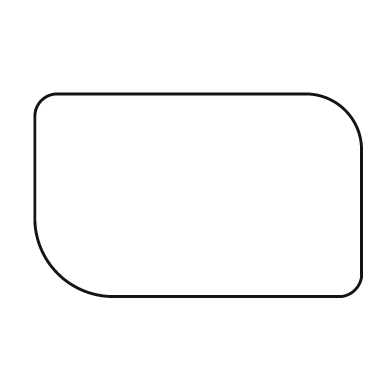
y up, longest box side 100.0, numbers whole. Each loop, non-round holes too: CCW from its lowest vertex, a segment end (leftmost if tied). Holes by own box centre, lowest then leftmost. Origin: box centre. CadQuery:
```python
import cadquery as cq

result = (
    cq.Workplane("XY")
    .moveTo(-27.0, -31.0)
    .lineTo(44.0, -31.0)
    .threePointArc((48.0, -29.0), (50.0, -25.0))
    .lineTo(50.0, 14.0)
    .threePointArc((45.0, 26.0), (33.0, 31.0))
    .lineTo(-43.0, 31.0)
    .threePointArc((-48.0, 29.0), (-50.0, 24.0))
    .lineTo(-50.0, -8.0)
    .threePointArc((-43.0, -24.0), (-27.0, -31.0))
    .close()
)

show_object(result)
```